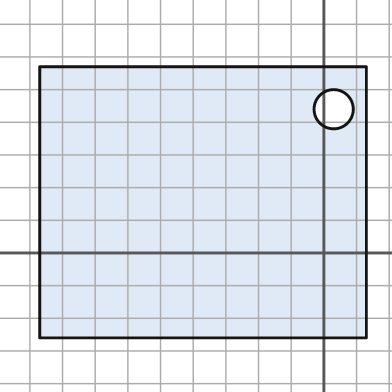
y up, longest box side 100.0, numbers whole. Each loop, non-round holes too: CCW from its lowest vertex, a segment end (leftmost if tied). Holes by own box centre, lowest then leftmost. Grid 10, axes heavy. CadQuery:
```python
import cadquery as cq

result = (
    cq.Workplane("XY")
    .moveTo(-87.0, -26.0)
    .lineTo(13.0, -26.0)
    .lineTo(13.0, 57.0)
    .lineTo(-87.0, 57.0)
    .close()
    .moveTo(3.0, 44.0)
    .circle(6.0)
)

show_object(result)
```